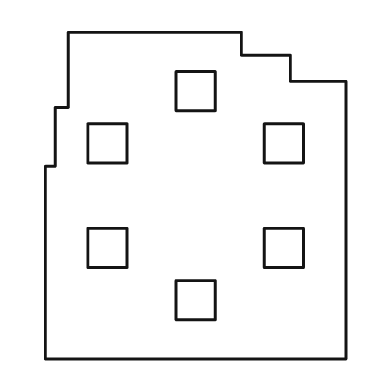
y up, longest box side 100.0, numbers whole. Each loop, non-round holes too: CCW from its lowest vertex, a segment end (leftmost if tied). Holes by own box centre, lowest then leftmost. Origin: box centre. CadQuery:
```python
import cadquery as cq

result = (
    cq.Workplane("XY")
    .moveTo(-46.0, -50.0)
    .lineTo(46.0, -50.0)
    .lineTo(46.0, 35.0)
    .lineTo(29.0, 35.0)
    .lineTo(29.0, 43.0)
    .lineTo(14.0, 43.0)
    .lineTo(14.0, 50.0)
    .lineTo(-39.0, 50.0)
    .lineTo(-39.0, 27.0)
    .lineTo(-43.0, 27.0)
    .lineTo(-43.0, 9.0)
    .lineTo(-46.0, 9.0)
    .close()
    .moveTo(-6.0, -38.0)
    .lineTo(6.0, -38.0)
    .lineTo(6.0, -26.0)
    .lineTo(-6.0, -26.0)
    .close()
    .moveTo(-33.0, -22.0)
    .lineTo(-21.0, -22.0)
    .lineTo(-21.0, -10.0)
    .lineTo(-33.0, -10.0)
    .close()
    .moveTo(21.0, -22.0)
    .lineTo(33.0, -22.0)
    .lineTo(33.0, -10.0)
    .lineTo(21.0, -10.0)
    .close()
    .moveTo(-33.0, 10.0)
    .lineTo(-21.0, 10.0)
    .lineTo(-21.0, 22.0)
    .lineTo(-33.0, 22.0)
    .close()
    .moveTo(21.0, 10.0)
    .lineTo(33.0, 10.0)
    .lineTo(33.0, 22.0)
    .lineTo(21.0, 22.0)
    .close()
    .moveTo(-6.0, 26.0)
    .lineTo(6.0, 26.0)
    .lineTo(6.0, 38.0)
    .lineTo(-6.0, 38.0)
    .close()
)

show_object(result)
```